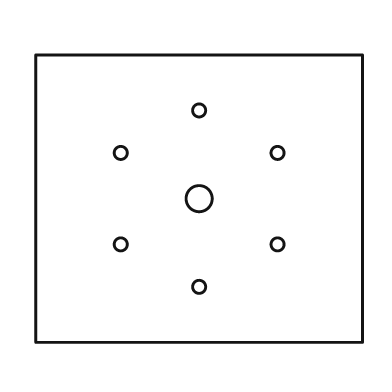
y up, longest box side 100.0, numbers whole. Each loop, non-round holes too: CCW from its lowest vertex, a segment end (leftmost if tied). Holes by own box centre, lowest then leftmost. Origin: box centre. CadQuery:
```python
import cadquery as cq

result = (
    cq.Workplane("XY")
    .moveTo(-50.0, -44.0)
    .lineTo(50.0, -44.0)
    .lineTo(50.0, 44.0)
    .lineTo(-50.0, 44.0)
    .close()
    .moveTo(0.0, -27.0)
    .circle(2.0)
    .moveTo(-24.0, -14.0)
    .circle(2.0)
    .moveTo(24.0, -14.0)
    .circle(2.0)
    .moveTo(0.0, 0.0)
    .circle(4.0)
    .moveTo(-24.0, 14.0)
    .circle(2.0)
    .moveTo(24.0, 14.0)
    .circle(2.0)
    .moveTo(0.0, 27.0)
    .circle(2.0)
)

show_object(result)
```